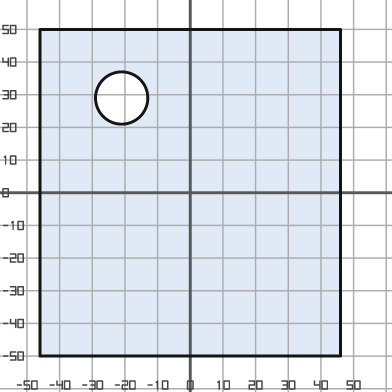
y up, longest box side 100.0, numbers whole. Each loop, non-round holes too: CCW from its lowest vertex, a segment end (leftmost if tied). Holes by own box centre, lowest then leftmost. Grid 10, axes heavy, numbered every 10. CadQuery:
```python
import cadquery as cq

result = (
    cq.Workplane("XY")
    .moveTo(-46.0, -50.0)
    .lineTo(46.0, -50.0)
    .lineTo(46.0, 50.0)
    .lineTo(-46.0, 50.0)
    .close()
    .moveTo(-21.0, 29.0)
    .circle(8.0)
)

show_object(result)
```